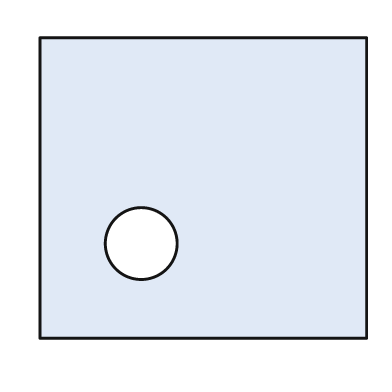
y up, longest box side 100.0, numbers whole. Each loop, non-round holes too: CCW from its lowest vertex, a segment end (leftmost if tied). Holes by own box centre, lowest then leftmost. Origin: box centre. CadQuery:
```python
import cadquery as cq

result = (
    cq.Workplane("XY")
    .moveTo(-50.0, -46.0)
    .lineTo(50.0, -46.0)
    .lineTo(50.0, 46.0)
    .lineTo(-50.0, 46.0)
    .close()
    .moveTo(-19.0, -17.0)
    .circle(11.0)
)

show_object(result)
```